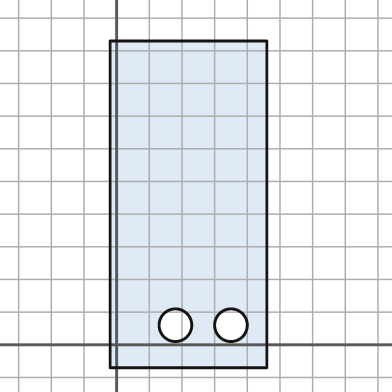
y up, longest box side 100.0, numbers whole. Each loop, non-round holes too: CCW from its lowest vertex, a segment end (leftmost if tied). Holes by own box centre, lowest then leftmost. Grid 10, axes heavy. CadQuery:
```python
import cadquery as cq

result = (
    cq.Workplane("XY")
    .moveTo(-2.0, -7.0)
    .lineTo(46.0, -7.0)
    .lineTo(46.0, 93.0)
    .lineTo(-2.0, 93.0)
    .close()
    .moveTo(18.0, 6.0)
    .circle(5.0)
    .moveTo(35.0, 6.0)
    .circle(5.0)
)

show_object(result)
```